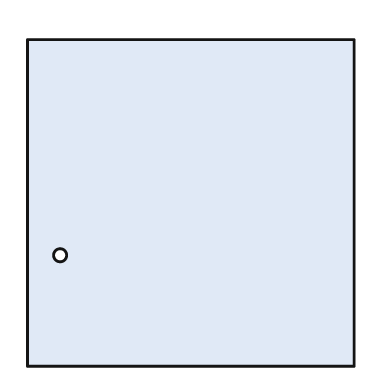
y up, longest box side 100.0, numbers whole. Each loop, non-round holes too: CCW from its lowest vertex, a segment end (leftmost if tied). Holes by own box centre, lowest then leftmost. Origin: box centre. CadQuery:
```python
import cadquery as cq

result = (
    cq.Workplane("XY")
    .moveTo(-50.0, -50.0)
    .lineTo(50.0, -50.0)
    .lineTo(50.0, 50.0)
    .lineTo(-50.0, 50.0)
    .close()
    .moveTo(-40.0, -16.0)
    .circle(2.0)
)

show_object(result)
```